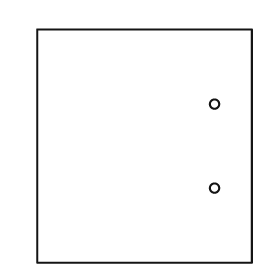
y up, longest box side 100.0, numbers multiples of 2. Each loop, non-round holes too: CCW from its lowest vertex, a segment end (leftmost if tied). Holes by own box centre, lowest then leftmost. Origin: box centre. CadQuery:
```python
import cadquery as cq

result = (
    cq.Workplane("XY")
    .moveTo(-46.0, -50.0)
    .lineTo(46.0, -50.0)
    .lineTo(46.0, 50.0)
    .lineTo(-46.0, 50.0)
    .close()
    .moveTo(30.0, -18.0)
    .circle(2.0)
    .moveTo(30.0, 18.0)
    .circle(2.0)
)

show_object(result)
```